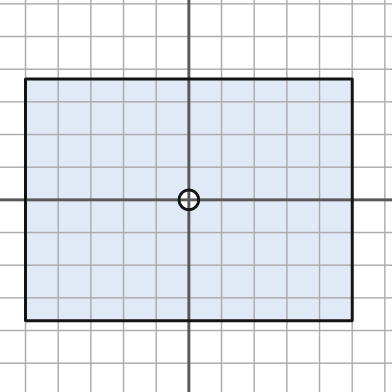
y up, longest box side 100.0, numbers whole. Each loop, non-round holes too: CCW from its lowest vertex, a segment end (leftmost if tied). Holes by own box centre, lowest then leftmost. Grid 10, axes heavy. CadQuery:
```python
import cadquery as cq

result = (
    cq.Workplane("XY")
    .moveTo(-50.0, -37.0)
    .lineTo(50.0, -37.0)
    .lineTo(50.0, 37.0)
    .lineTo(-50.0, 37.0)
    .close()
    .moveTo(0.0, 0.0)
    .circle(3.0)
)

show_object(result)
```